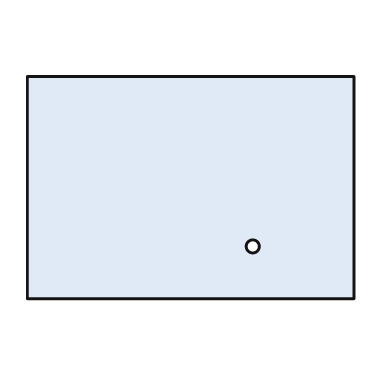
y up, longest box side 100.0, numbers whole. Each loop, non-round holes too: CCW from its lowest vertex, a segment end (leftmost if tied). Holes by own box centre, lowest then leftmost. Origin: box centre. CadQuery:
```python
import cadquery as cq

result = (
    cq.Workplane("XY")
    .moveTo(-50.0, -34.0)
    .lineTo(50.0, -34.0)
    .lineTo(50.0, 34.0)
    .lineTo(-50.0, 34.0)
    .close()
    .moveTo(19.0, -18.0)
    .circle(2.0)
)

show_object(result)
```